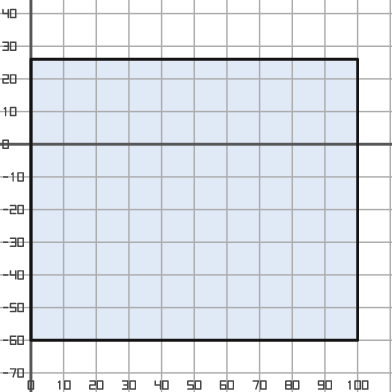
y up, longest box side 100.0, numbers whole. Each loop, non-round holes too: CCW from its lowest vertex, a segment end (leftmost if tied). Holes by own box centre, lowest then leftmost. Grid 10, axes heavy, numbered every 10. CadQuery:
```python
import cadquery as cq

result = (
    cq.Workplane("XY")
    .moveTo(0.0, -60.0)
    .lineTo(100.0, -60.0)
    .lineTo(100.0, 26.0)
    .lineTo(0.0, 26.0)
    .close()
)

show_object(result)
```